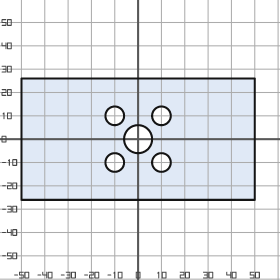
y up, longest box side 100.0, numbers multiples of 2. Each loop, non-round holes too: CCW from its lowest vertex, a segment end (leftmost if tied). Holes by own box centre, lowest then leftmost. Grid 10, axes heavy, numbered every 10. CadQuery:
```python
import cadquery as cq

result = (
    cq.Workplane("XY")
    .moveTo(-50.0, -26.0)
    .lineTo(50.0, -26.0)
    .lineTo(50.0, 26.0)
    .lineTo(-50.0, 26.0)
    .close()
    .moveTo(-10.0, -10.0)
    .circle(4.0)
    .moveTo(10.0, -10.0)
    .circle(4.0)
    .moveTo(0.0, 0.0)
    .circle(6.0)
    .moveTo(-10.0, 10.0)
    .circle(4.0)
    .moveTo(10.0, 10.0)
    .circle(4.0)
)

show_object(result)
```